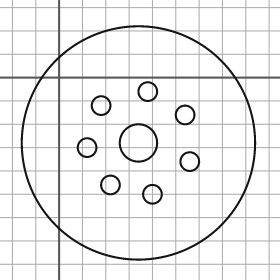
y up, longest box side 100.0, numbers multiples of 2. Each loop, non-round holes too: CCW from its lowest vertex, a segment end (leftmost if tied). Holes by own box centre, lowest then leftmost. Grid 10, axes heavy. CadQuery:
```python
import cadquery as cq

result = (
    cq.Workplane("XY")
    .moveTo(34.0, -28.0)
    .circle(50.0)
    .moveTo(40.0, -50.0)
    .circle(4.0)
    .moveTo(22.0, -46.0)
    .circle(4.0)
    .moveTo(56.0, -36.0)
    .circle(4.0)
    .moveTo(12.0, -30.0)
    .circle(4.0)
    .moveTo(34.0, -28.0)
    .circle(8.0)
    .moveTo(54.0, -16.0)
    .circle(4.0)
    .moveTo(18.0, -12.0)
    .circle(4.0)
    .moveTo(38.0, -6.0)
    .circle(4.0)
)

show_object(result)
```